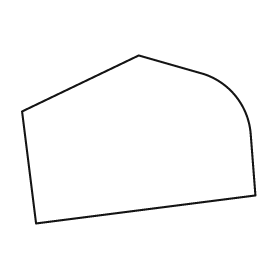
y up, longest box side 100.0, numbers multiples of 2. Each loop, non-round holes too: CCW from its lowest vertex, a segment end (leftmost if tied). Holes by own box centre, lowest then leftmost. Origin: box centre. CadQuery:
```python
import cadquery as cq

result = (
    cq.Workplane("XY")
    .moveTo(-44.0, -36.0)
    .lineTo(50.0, -24.0)
    .lineTo(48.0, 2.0)
    .threePointArc((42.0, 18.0), (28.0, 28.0))
    .lineTo(0.0, 36.0)
    .lineTo(-50.0, 12.0)
    .close()
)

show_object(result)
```